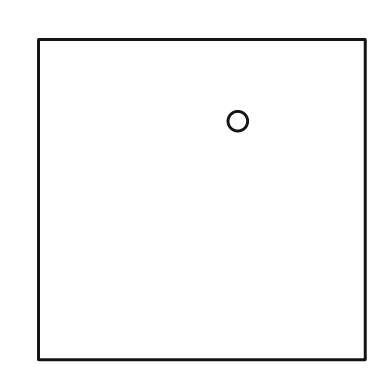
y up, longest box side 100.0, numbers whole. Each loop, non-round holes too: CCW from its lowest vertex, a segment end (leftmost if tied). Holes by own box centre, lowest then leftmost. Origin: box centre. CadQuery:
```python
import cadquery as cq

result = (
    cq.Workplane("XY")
    .moveTo(-50.0, -49.0)
    .lineTo(50.0, -49.0)
    .lineTo(50.0, 49.0)
    .lineTo(-50.0, 49.0)
    .close()
    .moveTo(11.0, 24.0)
    .circle(3.0)
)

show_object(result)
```